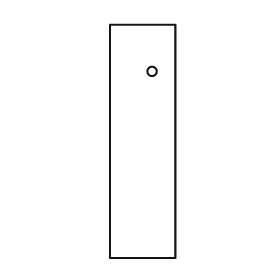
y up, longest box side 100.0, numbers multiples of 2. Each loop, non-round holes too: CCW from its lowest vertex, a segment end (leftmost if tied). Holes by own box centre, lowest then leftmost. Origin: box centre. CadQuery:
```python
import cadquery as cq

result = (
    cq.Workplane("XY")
    .moveTo(-14.0, -50.0)
    .lineTo(14.0, -50.0)
    .lineTo(14.0, 50.0)
    .lineTo(-14.0, 50.0)
    .close()
    .moveTo(4.0, 30.0)
    .circle(2.0)
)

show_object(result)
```